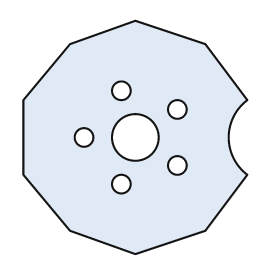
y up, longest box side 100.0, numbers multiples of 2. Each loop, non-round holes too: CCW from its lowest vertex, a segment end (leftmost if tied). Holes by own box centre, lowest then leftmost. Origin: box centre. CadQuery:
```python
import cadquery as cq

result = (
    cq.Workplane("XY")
    .moveTo(0.0, -50.0)
    .lineTo(30.0, -40.0)
    .lineTo(48.0, -16.0)
    .threePointArc((40.0, 0.0), (48.0, 16.0))
    .lineTo(30.0, 40.0)
    .lineTo(0.0, 50.0)
    .lineTo(-28.0, 40.0)
    .lineTo(-48.0, 16.0)
    .lineTo(-48.0, -16.0)
    .lineTo(-28.0, -40.0)
    .close()
    .moveTo(-6.0, -20.0)
    .circle(4.0)
    .moveTo(18.0, -12.0)
    .circle(4.0)
    .moveTo(-22.0, 0.0)
    .circle(4.0)
    .moveTo(0.0, 0.0)
    .circle(10.0)
    .moveTo(18.0, 12.0)
    .circle(4.0)
    .moveTo(-6.0, 20.0)
    .circle(4.0)
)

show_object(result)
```